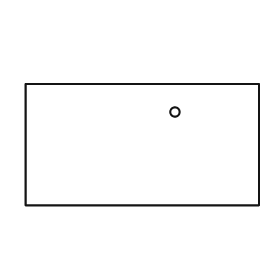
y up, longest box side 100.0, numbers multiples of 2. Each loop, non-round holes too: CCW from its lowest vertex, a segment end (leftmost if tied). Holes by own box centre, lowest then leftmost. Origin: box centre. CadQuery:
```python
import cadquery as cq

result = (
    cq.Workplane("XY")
    .moveTo(-50.0, -26.0)
    .lineTo(50.0, -26.0)
    .lineTo(50.0, 26.0)
    .lineTo(-50.0, 26.0)
    .close()
    .moveTo(14.0, 14.0)
    .circle(2.0)
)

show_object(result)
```